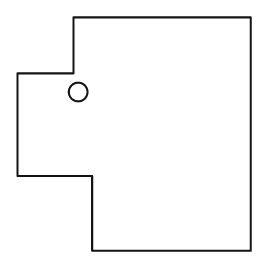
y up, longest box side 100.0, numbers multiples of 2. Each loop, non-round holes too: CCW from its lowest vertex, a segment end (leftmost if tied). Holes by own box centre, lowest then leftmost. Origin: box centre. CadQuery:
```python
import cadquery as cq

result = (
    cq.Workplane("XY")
    .moveTo(-18.0, -50.0)
    .lineTo(50.0, -50.0)
    .lineTo(50.0, 50.0)
    .lineTo(-26.0, 50.0)
    .lineTo(-26.0, 26.0)
    .lineTo(-50.0, 26.0)
    .lineTo(-50.0, -18.0)
    .lineTo(-18.0, -18.0)
    .close()
    .moveTo(-24.0, 18.0)
    .circle(4.0)
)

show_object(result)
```